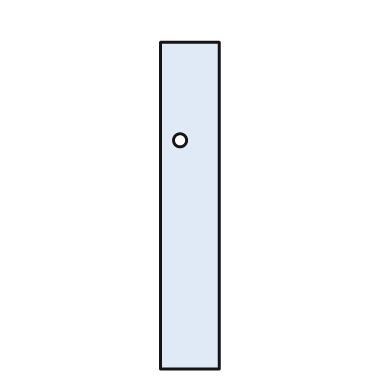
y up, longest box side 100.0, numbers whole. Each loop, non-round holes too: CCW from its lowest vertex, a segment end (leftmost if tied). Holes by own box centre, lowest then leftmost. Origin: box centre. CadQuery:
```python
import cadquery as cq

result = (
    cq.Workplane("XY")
    .moveTo(-9.0, -50.0)
    .lineTo(9.0, -50.0)
    .lineTo(9.0, 50.0)
    .lineTo(-9.0, 50.0)
    .close()
    .moveTo(-3.0, 20.0)
    .circle(2.0)
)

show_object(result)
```